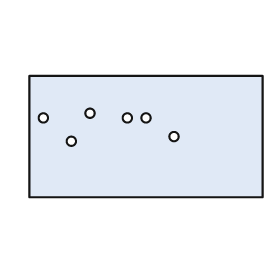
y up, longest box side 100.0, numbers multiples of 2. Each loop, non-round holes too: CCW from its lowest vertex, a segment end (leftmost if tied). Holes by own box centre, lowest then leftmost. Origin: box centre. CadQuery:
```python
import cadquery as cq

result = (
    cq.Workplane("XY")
    .moveTo(-50.0, -26.0)
    .lineTo(50.0, -26.0)
    .lineTo(50.0, 26.0)
    .lineTo(-50.0, 26.0)
    .close()
    .moveTo(-32.0, -2.0)
    .circle(2.0)
    .moveTo(12.0, 0.0)
    .circle(2.0)
    .moveTo(-44.0, 8.0)
    .circle(2.0)
    .moveTo(-8.0, 8.0)
    .circle(2.0)
    .moveTo(0.0, 8.0)
    .circle(2.0)
    .moveTo(-24.0, 10.0)
    .circle(2.0)
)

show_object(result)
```